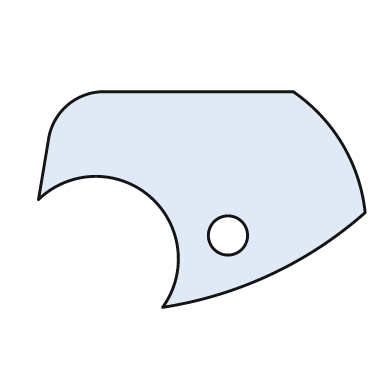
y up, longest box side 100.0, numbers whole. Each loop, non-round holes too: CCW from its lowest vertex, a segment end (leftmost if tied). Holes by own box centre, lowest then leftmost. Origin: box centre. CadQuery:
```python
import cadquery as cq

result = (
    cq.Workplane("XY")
    .moveTo(-12.0, -33.0)
    .threePointArc((21.0, -23.0), (50.0, -4.0))
    .threePointArc((43.0, 17.0), (28.0, 33.0))
    .lineTo(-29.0, 33.0)
    .threePointArc((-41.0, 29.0), (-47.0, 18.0))
    .lineTo(-50.0, 0.0)
    .threePointArc((-16.0, 1.0), (-12.0, -33.0))
    .close()
    .moveTo(8.0, -11.0)
    .circle(6.0)
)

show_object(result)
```